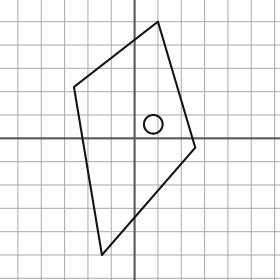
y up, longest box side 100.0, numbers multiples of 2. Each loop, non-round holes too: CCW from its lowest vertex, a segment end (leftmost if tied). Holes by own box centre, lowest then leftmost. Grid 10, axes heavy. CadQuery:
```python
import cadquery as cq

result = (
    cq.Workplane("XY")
    .moveTo(-14.0, -50.0)
    .lineTo(26.0, -4.0)
    .lineTo(10.0, 50.0)
    .lineTo(-26.0, 22.0)
    .close()
    .moveTo(8.0, 6.0)
    .circle(4.0)
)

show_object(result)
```